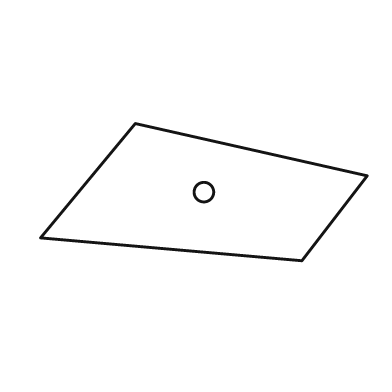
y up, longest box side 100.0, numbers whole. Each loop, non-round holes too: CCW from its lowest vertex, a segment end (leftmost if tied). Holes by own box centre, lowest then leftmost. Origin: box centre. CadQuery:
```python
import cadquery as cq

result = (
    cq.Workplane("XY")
    .moveTo(30.0, -21.0)
    .lineTo(50.0, 5.0)
    .lineTo(-21.0, 21.0)
    .lineTo(-50.0, -14.0)
    .close()
    .moveTo(0.0, 0.0)
    .circle(3.0)
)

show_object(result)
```